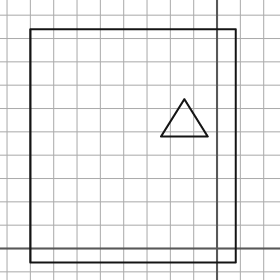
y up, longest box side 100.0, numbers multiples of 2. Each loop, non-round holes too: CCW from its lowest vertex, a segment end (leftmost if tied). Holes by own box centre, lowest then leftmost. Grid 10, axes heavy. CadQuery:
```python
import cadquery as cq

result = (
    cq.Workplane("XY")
    .moveTo(-80.0, -6.0)
    .lineTo(8.0, -6.0)
    .lineTo(8.0, 94.0)
    .lineTo(-80.0, 94.0)
    .close()
    .moveTo(-24.0, 48.0)
    .lineTo(-4.0, 48.0)
    .lineTo(-14.0, 64.0)
    .close()
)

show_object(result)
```